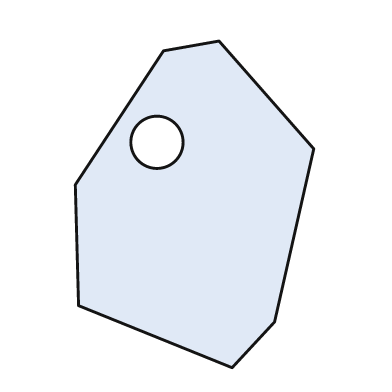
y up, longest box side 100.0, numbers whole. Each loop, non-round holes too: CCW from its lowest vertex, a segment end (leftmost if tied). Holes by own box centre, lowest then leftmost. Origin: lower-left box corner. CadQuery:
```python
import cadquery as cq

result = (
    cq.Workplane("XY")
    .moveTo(48.0, 0.0)
    .lineTo(61.0, 14.0)
    .lineTo(73.0, 67.0)
    .lineTo(44.0, 100.0)
    .lineTo(27.0, 97.0)
    .lineTo(0.0, 56.0)
    .lineTo(1.0, 19.0)
    .close()
    .moveTo(25.0, 69.0)
    .circle(8.0)
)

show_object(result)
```